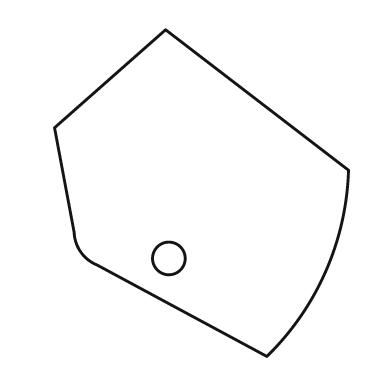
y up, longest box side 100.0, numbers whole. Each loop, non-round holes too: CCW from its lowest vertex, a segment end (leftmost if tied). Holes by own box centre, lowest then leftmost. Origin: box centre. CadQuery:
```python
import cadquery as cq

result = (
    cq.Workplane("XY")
    .moveTo(20.0, -50.0)
    .threePointArc((38.0, -24.0), (45.0, 7.0))
    .lineTo(-11.0, 50.0)
    .lineTo(-45.0, 20.0)
    .lineTo(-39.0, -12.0)
    .threePointArc((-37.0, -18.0), (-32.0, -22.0))
    .close()
    .moveTo(-10.0, -20.0)
    .circle(5.0)
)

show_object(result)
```